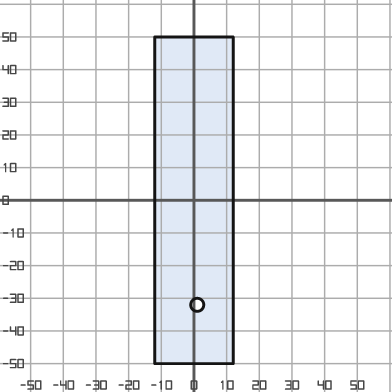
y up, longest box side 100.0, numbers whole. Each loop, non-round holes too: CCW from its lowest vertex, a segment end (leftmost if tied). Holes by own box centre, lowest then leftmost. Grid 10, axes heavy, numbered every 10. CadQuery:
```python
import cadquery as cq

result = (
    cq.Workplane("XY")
    .moveTo(-12.0, -50.0)
    .lineTo(12.0, -50.0)
    .lineTo(12.0, 50.0)
    .lineTo(-12.0, 50.0)
    .close()
    .moveTo(1.0, -32.0)
    .circle(2.0)
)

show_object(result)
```